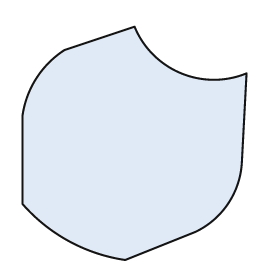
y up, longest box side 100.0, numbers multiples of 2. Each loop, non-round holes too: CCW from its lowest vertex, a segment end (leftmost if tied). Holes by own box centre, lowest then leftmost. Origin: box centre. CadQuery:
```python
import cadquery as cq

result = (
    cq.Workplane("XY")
    .moveTo(-4.0, -50.0)
    .lineTo(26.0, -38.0)
    .threePointArc((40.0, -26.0), (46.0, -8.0))
    .lineTo(48.0, 30.0)
    .threePointArc((20.0, 30.0), (0.0, 50.0))
    .lineTo(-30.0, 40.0)
    .threePointArc((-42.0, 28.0), (-48.0, 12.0))
    .lineTo(-48.0, -26.0)
    .threePointArc((-28.0, -42.0), (-4.0, -50.0))
    .close()
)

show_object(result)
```